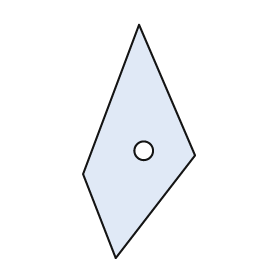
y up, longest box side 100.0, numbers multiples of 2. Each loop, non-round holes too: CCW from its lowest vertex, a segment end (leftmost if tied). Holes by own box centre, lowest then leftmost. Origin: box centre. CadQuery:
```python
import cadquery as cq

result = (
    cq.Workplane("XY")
    .moveTo(-10.0, -50.0)
    .lineTo(24.0, -6.0)
    .lineTo(0.0, 50.0)
    .lineTo(-24.0, -14.0)
    .close()
    .moveTo(2.0, -4.0)
    .circle(4.0)
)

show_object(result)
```